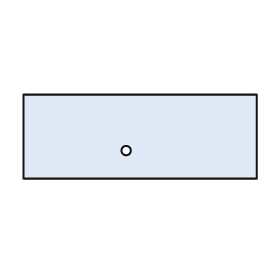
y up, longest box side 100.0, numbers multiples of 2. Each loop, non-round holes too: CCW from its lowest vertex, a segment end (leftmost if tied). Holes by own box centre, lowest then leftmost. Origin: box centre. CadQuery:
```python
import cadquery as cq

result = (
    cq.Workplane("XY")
    .moveTo(-50.0, -18.0)
    .lineTo(50.0, -18.0)
    .lineTo(50.0, 18.0)
    .lineTo(-50.0, 18.0)
    .close()
    .moveTo(-6.0, -6.0)
    .circle(2.0)
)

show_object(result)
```